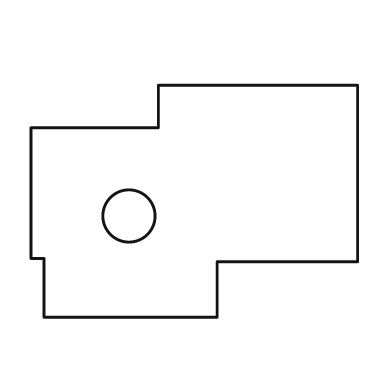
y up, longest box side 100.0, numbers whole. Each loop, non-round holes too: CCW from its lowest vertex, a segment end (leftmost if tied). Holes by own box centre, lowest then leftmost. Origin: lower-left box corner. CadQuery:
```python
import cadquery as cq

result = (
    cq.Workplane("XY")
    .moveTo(4.0, 0.0)
    .lineTo(57.0, 0.0)
    .lineTo(57.0, 17.0)
    .lineTo(100.0, 17.0)
    .lineTo(100.0, 71.0)
    .lineTo(39.0, 71.0)
    .lineTo(39.0, 58.0)
    .lineTo(0.0, 58.0)
    .lineTo(0.0, 18.0)
    .lineTo(4.0, 18.0)
    .close()
    .moveTo(30.0, 31.0)
    .circle(8.0)
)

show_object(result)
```